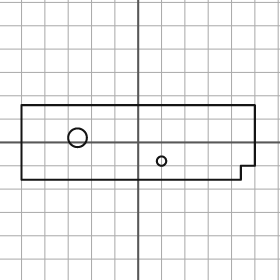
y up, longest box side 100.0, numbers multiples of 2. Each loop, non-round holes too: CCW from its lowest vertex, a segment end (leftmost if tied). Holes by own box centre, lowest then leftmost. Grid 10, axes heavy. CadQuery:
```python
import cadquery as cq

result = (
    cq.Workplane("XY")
    .moveTo(-50.0, -16.0)
    .lineTo(44.0, -16.0)
    .lineTo(44.0, -10.0)
    .lineTo(50.0, -10.0)
    .lineTo(50.0, 16.0)
    .lineTo(-50.0, 16.0)
    .close()
    .moveTo(10.0, -8.0)
    .circle(2.0)
    .moveTo(-26.0, 2.0)
    .circle(4.0)
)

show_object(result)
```